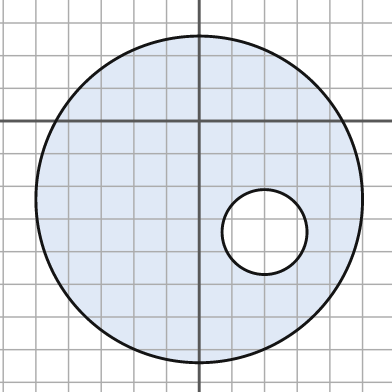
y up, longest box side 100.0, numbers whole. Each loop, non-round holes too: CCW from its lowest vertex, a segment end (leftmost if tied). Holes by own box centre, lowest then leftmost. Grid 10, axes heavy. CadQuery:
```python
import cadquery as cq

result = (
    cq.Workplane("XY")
    .moveTo(0.0, -24.0)
    .circle(50.0)
    .moveTo(20.0, -34.0)
    .circle(13.0)
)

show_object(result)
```